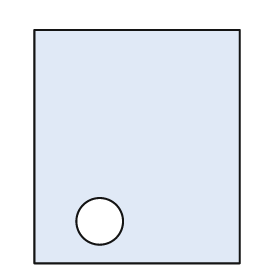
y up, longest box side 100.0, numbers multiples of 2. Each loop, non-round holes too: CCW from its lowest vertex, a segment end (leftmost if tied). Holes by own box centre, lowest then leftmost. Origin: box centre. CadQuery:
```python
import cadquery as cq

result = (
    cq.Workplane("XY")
    .moveTo(-44.0, -50.0)
    .lineTo(44.0, -50.0)
    .lineTo(44.0, 50.0)
    .lineTo(-44.0, 50.0)
    .close()
    .moveTo(-16.0, -32.0)
    .circle(10.0)
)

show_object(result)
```